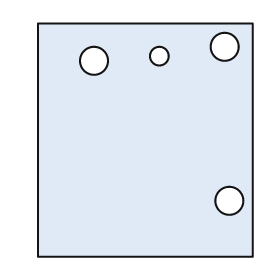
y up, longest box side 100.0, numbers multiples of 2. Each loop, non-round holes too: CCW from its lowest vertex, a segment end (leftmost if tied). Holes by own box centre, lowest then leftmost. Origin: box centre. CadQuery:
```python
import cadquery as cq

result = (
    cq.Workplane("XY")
    .moveTo(-46.0, -50.0)
    .lineTo(46.0, -50.0)
    .lineTo(46.0, 50.0)
    .lineTo(-46.0, 50.0)
    .close()
    .moveTo(36.0, -26.0)
    .circle(6.0)
    .moveTo(-22.0, 34.0)
    .circle(6.0)
    .moveTo(6.0, 36.0)
    .circle(4.0)
    .moveTo(34.0, 40.0)
    .circle(6.0)
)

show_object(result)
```